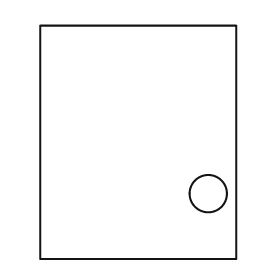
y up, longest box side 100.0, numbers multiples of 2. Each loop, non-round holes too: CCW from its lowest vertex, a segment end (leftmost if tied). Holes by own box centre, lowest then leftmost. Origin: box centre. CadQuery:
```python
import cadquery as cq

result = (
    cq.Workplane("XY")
    .moveTo(-42.0, -50.0)
    .lineTo(42.0, -50.0)
    .lineTo(42.0, 50.0)
    .lineTo(-42.0, 50.0)
    .close()
    .moveTo(30.0, -22.0)
    .circle(8.0)
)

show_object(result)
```